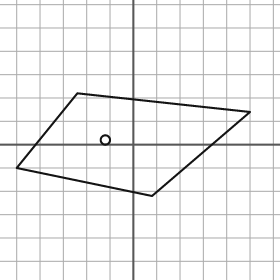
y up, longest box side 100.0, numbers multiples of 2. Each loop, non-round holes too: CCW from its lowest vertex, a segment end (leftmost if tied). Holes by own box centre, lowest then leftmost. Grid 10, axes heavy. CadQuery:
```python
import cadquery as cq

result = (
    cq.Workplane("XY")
    .moveTo(8.0, -22.0)
    .lineTo(50.0, 14.0)
    .lineTo(-24.0, 22.0)
    .lineTo(-50.0, -10.0)
    .close()
    .moveTo(-12.0, 2.0)
    .circle(2.0)
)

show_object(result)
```